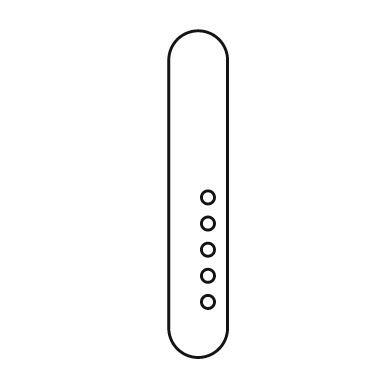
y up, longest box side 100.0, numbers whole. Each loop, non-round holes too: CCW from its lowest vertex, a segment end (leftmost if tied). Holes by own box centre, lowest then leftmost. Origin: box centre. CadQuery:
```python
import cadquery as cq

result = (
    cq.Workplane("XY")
    .moveTo(-9.0, -41.0)
    .threePointArc((0.0, -50.0), (9.0, -41.0))
    .lineTo(9.0, 41.0)
    .threePointArc((0.0, 50.0), (-9.0, 41.0))
    .close()
    .moveTo(3.0, -33.0)
    .circle(2.0)
    .moveTo(3.0, -25.0)
    .circle(2.0)
    .moveTo(3.0, -17.0)
    .circle(2.0)
    .moveTo(3.0, -9.0)
    .circle(2.0)
    .moveTo(3.0, -1.0)
    .circle(2.0)
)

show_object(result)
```